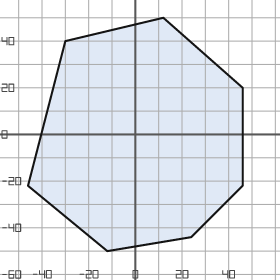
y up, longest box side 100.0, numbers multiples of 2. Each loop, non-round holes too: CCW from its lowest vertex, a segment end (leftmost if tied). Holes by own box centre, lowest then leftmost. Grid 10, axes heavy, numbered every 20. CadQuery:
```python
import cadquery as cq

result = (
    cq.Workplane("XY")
    .moveTo(-12.0, -50.0)
    .lineTo(24.0, -44.0)
    .lineTo(46.0, -22.0)
    .lineTo(46.0, 20.0)
    .lineTo(12.0, 50.0)
    .lineTo(-30.0, 40.0)
    .lineTo(-46.0, -22.0)
    .close()
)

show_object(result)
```